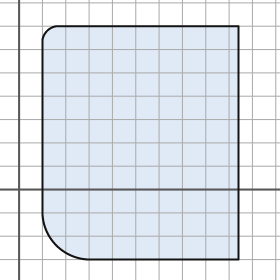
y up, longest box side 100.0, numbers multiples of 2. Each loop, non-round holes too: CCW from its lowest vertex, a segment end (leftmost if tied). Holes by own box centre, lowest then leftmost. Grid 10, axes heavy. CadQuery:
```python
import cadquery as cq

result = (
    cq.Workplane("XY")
    .moveTo(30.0, -30.0)
    .lineTo(94.0, -30.0)
    .lineTo(94.0, 70.0)
    .lineTo(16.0, 70.0)
    .threePointArc((12.0, 68.0), (10.0, 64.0))
    .lineTo(10.0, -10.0)
    .threePointArc((16.0, -24.0), (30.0, -30.0))
    .close()
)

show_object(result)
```